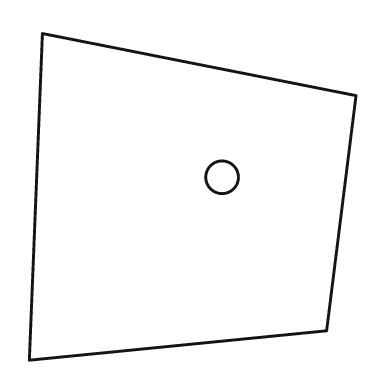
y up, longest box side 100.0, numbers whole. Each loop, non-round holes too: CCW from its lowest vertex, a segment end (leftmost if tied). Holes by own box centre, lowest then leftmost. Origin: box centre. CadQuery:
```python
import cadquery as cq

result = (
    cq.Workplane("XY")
    .moveTo(-50.0, -50.0)
    .lineTo(41.0, -41.0)
    .lineTo(50.0, 31.0)
    .lineTo(-46.0, 50.0)
    .close()
    .moveTo(9.0, 6.0)
    .circle(5.0)
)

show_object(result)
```